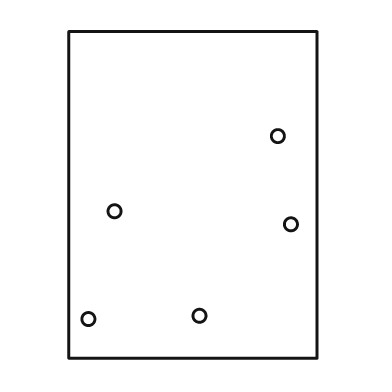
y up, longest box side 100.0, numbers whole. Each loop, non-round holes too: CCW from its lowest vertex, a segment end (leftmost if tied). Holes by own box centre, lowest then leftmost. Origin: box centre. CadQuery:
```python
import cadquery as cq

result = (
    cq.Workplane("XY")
    .moveTo(-38.0, -50.0)
    .lineTo(38.0, -50.0)
    .lineTo(38.0, 50.0)
    .lineTo(-38.0, 50.0)
    .close()
    .moveTo(-32.0, -38.0)
    .circle(2.0)
    .moveTo(2.0, -37.0)
    .circle(2.0)
    .moveTo(30.0, -9.0)
    .circle(2.0)
    .moveTo(-24.0, -5.0)
    .circle(2.0)
    .moveTo(26.0, 18.0)
    .circle(2.0)
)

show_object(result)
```